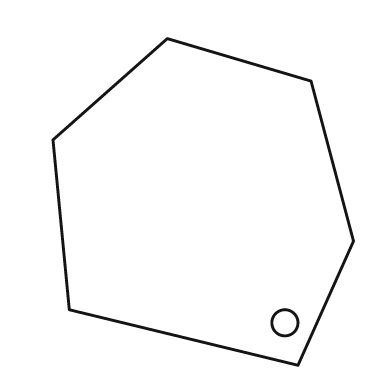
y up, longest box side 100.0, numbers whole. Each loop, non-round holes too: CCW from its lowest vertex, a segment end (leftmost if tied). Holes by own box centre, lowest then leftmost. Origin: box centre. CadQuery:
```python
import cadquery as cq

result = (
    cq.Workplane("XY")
    .moveTo(29.0, -50.0)
    .lineTo(46.0, -12.0)
    .lineTo(33.0, 37.0)
    .lineTo(-11.0, 50.0)
    .lineTo(-46.0, 19.0)
    .lineTo(-41.0, -33.0)
    .close()
    .moveTo(25.0, -37.0)
    .circle(4.0)
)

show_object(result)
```